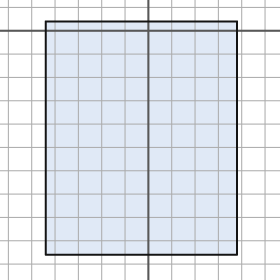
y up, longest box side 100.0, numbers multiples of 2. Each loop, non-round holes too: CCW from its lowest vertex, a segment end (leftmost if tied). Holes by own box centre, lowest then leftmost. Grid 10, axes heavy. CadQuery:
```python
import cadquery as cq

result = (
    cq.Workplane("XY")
    .moveTo(-44.0, -96.0)
    .lineTo(38.0, -96.0)
    .lineTo(38.0, 4.0)
    .lineTo(-44.0, 4.0)
    .close()
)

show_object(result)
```